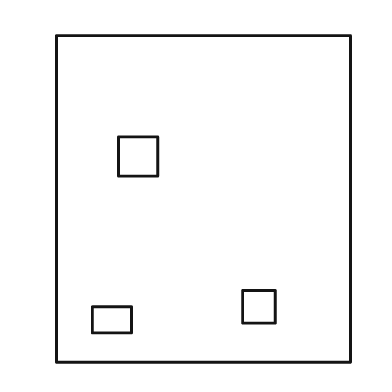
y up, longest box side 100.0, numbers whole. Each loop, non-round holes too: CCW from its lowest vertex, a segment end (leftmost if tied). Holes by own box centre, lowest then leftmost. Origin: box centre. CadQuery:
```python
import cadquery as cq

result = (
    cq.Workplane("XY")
    .moveTo(-45.0, -50.0)
    .lineTo(45.0, -50.0)
    .lineTo(45.0, 50.0)
    .lineTo(-45.0, 50.0)
    .close()
    .moveTo(-34.0, -41.0)
    .lineTo(-22.0, -41.0)
    .lineTo(-22.0, -33.0)
    .lineTo(-34.0, -33.0)
    .close()
    .moveTo(12.0, -38.0)
    .lineTo(22.0, -38.0)
    .lineTo(22.0, -28.0)
    .lineTo(12.0, -28.0)
    .close()
    .moveTo(-26.0, 7.0)
    .lineTo(-14.0, 7.0)
    .lineTo(-14.0, 19.0)
    .lineTo(-26.0, 19.0)
    .close()
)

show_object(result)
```